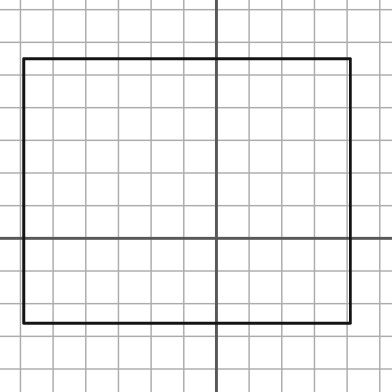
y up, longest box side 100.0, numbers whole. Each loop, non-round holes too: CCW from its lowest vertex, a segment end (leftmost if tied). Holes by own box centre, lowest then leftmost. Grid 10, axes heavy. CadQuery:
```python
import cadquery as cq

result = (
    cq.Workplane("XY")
    .moveTo(-59.0, -26.0)
    .lineTo(41.0, -26.0)
    .lineTo(41.0, 55.0)
    .lineTo(-59.0, 55.0)
    .close()
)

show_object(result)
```